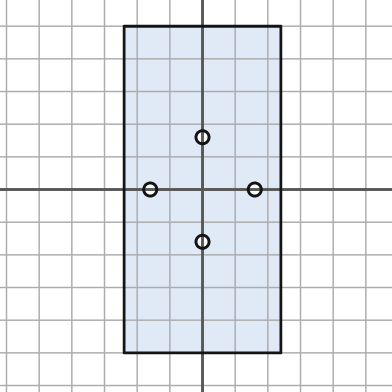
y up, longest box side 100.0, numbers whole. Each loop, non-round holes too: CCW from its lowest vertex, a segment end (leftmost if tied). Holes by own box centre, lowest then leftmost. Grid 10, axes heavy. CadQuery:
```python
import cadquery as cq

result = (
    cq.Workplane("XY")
    .moveTo(-24.0, -50.0)
    .lineTo(24.0, -50.0)
    .lineTo(24.0, 50.0)
    .lineTo(-24.0, 50.0)
    .close()
    .moveTo(0.0, -16.0)
    .circle(2.0)
    .moveTo(-16.0, 0.0)
    .circle(2.0)
    .moveTo(16.0, 0.0)
    .circle(2.0)
    .moveTo(0.0, 16.0)
    .circle(2.0)
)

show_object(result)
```